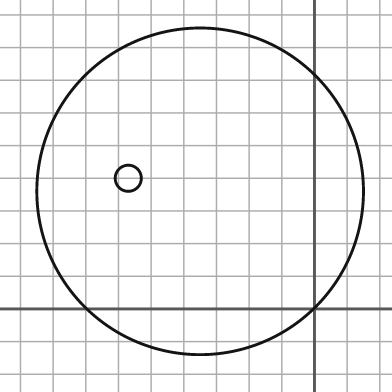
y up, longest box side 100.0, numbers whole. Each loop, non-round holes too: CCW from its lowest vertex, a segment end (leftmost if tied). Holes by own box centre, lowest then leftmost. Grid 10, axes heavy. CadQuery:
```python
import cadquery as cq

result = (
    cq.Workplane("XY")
    .moveTo(-35.0, 36.0)
    .circle(50.0)
    .moveTo(-57.0, 40.0)
    .circle(4.0)
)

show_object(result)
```